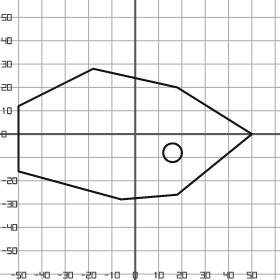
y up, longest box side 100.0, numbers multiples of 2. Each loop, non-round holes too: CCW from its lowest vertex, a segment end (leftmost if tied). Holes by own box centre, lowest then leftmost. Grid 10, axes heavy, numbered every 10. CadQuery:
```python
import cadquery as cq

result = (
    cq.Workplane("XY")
    .moveTo(-6.0, -28.0)
    .lineTo(18.0, -26.0)
    .lineTo(50.0, 0.0)
    .lineTo(18.0, 20.0)
    .lineTo(-18.0, 28.0)
    .lineTo(-50.0, 12.0)
    .lineTo(-50.0, -16.0)
    .close()
    .moveTo(16.0, -8.0)
    .circle(4.0)
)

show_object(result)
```